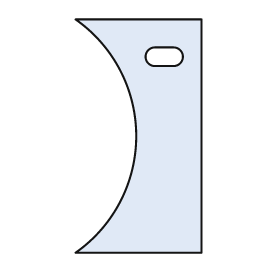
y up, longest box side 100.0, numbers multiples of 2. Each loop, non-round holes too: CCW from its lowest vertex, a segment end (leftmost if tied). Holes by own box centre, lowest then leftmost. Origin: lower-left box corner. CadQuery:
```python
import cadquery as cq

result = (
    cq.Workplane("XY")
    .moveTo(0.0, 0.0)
    .lineTo(54.0, 0.0)
    .lineTo(54.0, 100.0)
    .lineTo(0.0, 100.0)
    .threePointArc((26.0, 50.0), (0.0, 0.0))
    .close()
    .moveTo(34.0, 80.0)
    .lineTo(42.0, 80.0)
    .threePointArc((46.0, 84.0), (42.0, 88.0))
    .lineTo(34.0, 88.0)
    .threePointArc((30.0, 84.0), (34.0, 80.0))
    .close()
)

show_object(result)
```